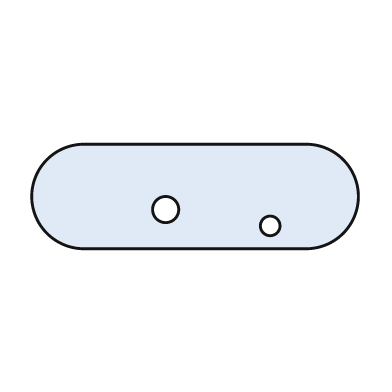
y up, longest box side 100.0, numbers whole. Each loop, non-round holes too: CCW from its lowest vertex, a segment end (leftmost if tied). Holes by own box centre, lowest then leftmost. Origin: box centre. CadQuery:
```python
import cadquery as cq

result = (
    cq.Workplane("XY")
    .moveTo(-34.0, -16.0)
    .lineTo(34.0, -16.0)
    .threePointArc((50.0, 0.0), (34.0, 16.0))
    .lineTo(-34.0, 16.0)
    .threePointArc((-50.0, 0.0), (-34.0, -16.0))
    .close()
    .moveTo(23.0, -9.0)
    .circle(3.0)
    .moveTo(-9.0, -4.0)
    .circle(4.0)
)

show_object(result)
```